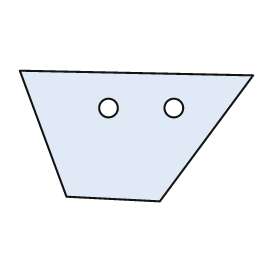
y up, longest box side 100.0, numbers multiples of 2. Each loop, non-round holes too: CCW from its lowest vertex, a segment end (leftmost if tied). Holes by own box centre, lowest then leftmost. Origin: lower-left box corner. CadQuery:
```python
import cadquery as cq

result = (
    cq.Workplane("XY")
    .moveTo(60.0, 0.0)
    .lineTo(100.0, 54.0)
    .lineTo(0.0, 56.0)
    .lineTo(20.0, 2.0)
    .close()
    .moveTo(38.0, 40.0)
    .circle(4.0)
    .moveTo(66.0, 40.0)
    .circle(4.0)
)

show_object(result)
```